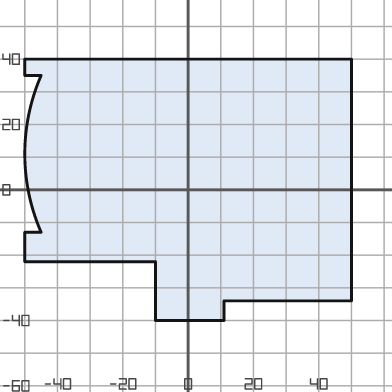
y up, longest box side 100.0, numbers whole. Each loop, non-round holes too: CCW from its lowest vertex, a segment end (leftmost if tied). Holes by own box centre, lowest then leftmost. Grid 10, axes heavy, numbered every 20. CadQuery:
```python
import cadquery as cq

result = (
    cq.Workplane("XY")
    .moveTo(-10.0, -40.0)
    .lineTo(11.0, -40.0)
    .lineTo(11.0, -34.0)
    .lineTo(50.0, -34.0)
    .lineTo(50.0, 40.0)
    .lineTo(-50.0, 40.0)
    .lineTo(-50.0, 35.0)
    .lineTo(-45.0, 35.0)
    .threePointArc((-50.0, 11.0), (-45.0, -13.0))
    .lineTo(-50.0, -13.0)
    .lineTo(-50.0, -22.0)
    .lineTo(-10.0, -22.0)
    .close()
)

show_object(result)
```